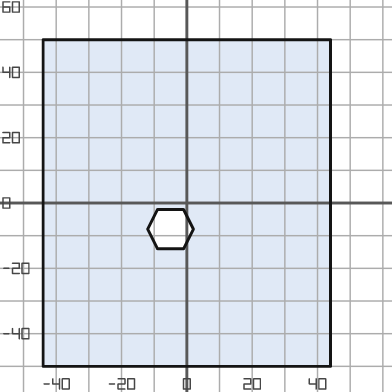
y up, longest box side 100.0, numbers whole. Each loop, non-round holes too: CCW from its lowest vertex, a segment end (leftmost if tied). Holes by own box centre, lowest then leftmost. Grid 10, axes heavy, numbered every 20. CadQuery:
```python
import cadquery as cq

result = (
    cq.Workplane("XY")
    .moveTo(-44.0, -50.0)
    .lineTo(44.0, -50.0)
    .lineTo(44.0, 50.0)
    .lineTo(-44.0, 50.0)
    .close()
    .moveTo(-9.0, -14.0)
    .lineTo(-1.0, -14.0)
    .lineTo(2.0, -8.0)
    .lineTo(-1.0, -2.0)
    .lineTo(-9.0, -2.0)
    .lineTo(-12.0, -8.0)
    .close()
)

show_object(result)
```